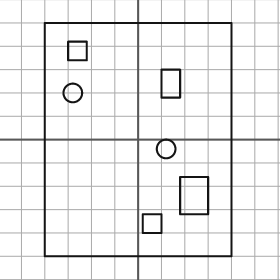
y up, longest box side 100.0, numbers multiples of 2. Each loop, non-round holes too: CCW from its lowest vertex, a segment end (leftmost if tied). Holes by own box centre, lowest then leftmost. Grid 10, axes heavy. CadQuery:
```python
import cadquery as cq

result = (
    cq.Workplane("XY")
    .moveTo(-40.0, -50.0)
    .lineTo(40.0, -50.0)
    .lineTo(40.0, 50.0)
    .lineTo(-40.0, 50.0)
    .close()
    .moveTo(2.0, -40.0)
    .lineTo(10.0, -40.0)
    .lineTo(10.0, -32.0)
    .lineTo(2.0, -32.0)
    .close()
    .moveTo(18.0, -32.0)
    .lineTo(30.0, -32.0)
    .lineTo(30.0, -16.0)
    .lineTo(18.0, -16.0)
    .close()
    .moveTo(12.0, -4.0)
    .circle(4.0)
    .moveTo(-28.0, 20.0)
    .circle(4.0)
    .moveTo(10.0, 18.0)
    .lineTo(18.0, 18.0)
    .lineTo(18.0, 30.0)
    .lineTo(10.0, 30.0)
    .close()
    .moveTo(-30.0, 34.0)
    .lineTo(-22.0, 34.0)
    .lineTo(-22.0, 42.0)
    .lineTo(-30.0, 42.0)
    .close()
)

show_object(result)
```